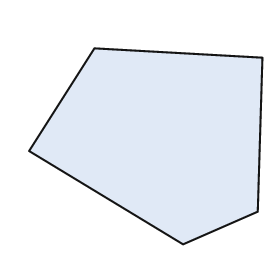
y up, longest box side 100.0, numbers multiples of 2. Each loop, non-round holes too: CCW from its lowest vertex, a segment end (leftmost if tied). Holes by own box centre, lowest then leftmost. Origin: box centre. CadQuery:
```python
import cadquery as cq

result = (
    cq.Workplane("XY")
    .moveTo(16.0, -42.0)
    .lineTo(48.0, -28.0)
    .lineTo(50.0, 38.0)
    .lineTo(-22.0, 42.0)
    .lineTo(-50.0, -2.0)
    .close()
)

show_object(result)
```